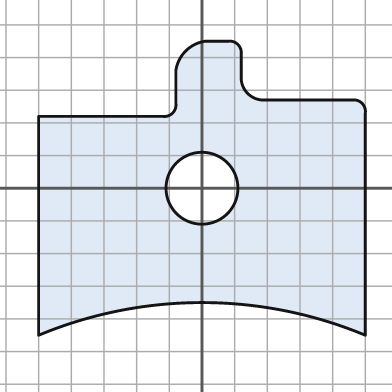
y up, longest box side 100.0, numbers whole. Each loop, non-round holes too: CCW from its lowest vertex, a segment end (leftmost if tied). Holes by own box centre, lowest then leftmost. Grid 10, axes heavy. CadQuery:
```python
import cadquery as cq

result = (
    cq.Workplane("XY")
    .moveTo(-50.0, -45.0)
    .threePointArc((0.0, -35.0), (50.0, -45.0))
    .lineTo(50.0, 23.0)
    .threePointArc((49.0, 26.0), (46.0, 27.0))
    .lineTo(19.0, 27.0)
    .threePointArc((14.0, 29.0), (12.0, 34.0))
    .lineTo(12.0, 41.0)
    .threePointArc((11.0, 44.0), (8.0, 45.0))
    .lineTo(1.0, 45.0)
    .threePointArc((-5.0, 42.0), (-8.0, 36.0))
    .lineTo(-8.0, 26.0)
    .threePointArc((-9.0, 23.0), (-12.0, 22.0))
    .lineTo(-50.0, 22.0)
    .close()
    .moveTo(0.0, 0.0)
    .circle(11.0)
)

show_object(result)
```